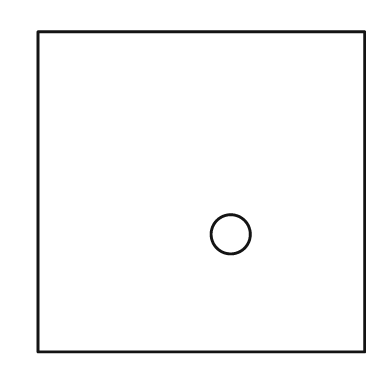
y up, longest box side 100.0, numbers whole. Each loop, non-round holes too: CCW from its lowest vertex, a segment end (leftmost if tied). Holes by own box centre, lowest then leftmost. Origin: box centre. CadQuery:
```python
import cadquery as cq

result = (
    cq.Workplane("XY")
    .moveTo(-50.0, -49.0)
    .lineTo(50.0, -49.0)
    .lineTo(50.0, 49.0)
    .lineTo(-50.0, 49.0)
    .close()
    .moveTo(9.0, -13.0)
    .circle(6.0)
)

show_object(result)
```